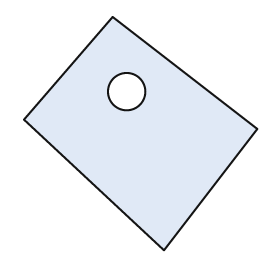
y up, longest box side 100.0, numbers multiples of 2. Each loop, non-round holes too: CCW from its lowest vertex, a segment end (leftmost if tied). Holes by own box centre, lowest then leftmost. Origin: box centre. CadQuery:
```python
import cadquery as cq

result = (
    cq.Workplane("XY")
    .moveTo(10.0, -50.0)
    .lineTo(50.0, 2.0)
    .lineTo(-12.0, 50.0)
    .lineTo(-50.0, 6.0)
    .close()
    .moveTo(-6.0, 18.0)
    .circle(8.0)
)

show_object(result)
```